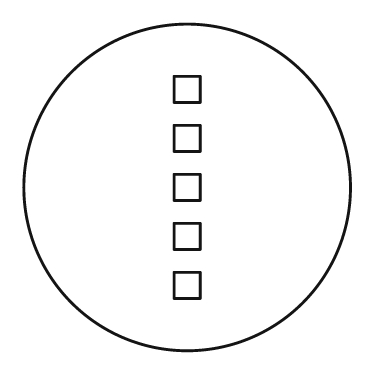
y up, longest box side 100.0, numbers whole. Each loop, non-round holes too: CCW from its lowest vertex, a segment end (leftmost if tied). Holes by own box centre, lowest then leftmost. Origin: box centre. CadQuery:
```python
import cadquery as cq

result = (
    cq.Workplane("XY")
    .moveTo(0.0, 0.0)
    .circle(50.0)
    .moveTo(-4.0, -34.0)
    .lineTo(4.0, -34.0)
    .lineTo(4.0, -26.0)
    .lineTo(-4.0, -26.0)
    .close()
    .moveTo(-4.0, -19.0)
    .lineTo(4.0, -19.0)
    .lineTo(4.0, -11.0)
    .lineTo(-4.0, -11.0)
    .close()
    .moveTo(-4.0, -4.0)
    .lineTo(4.0, -4.0)
    .lineTo(4.0, 4.0)
    .lineTo(-4.0, 4.0)
    .close()
    .moveTo(-4.0, 11.0)
    .lineTo(4.0, 11.0)
    .lineTo(4.0, 19.0)
    .lineTo(-4.0, 19.0)
    .close()
    .moveTo(-4.0, 26.0)
    .lineTo(4.0, 26.0)
    .lineTo(4.0, 34.0)
    .lineTo(-4.0, 34.0)
    .close()
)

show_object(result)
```